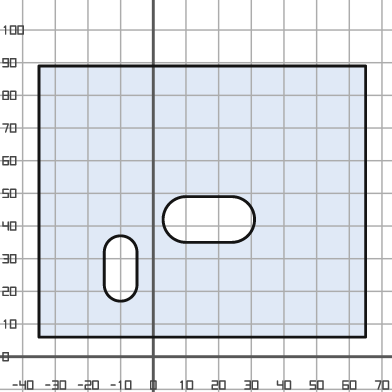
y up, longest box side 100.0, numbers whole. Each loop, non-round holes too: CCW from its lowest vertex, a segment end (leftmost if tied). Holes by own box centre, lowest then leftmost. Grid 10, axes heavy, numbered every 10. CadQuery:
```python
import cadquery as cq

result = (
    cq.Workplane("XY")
    .moveTo(-35.0, 6.0)
    .lineTo(65.0, 6.0)
    .lineTo(65.0, 89.0)
    .lineTo(-35.0, 89.0)
    .close()
    .moveTo(-15.0, 22.0)
    .threePointArc((-10.0, 17.0), (-5.0, 22.0))
    .lineTo(-5.0, 32.0)
    .threePointArc((-10.0, 37.0), (-15.0, 32.0))
    .close()
    .moveTo(10.0, 35.0)
    .lineTo(24.0, 35.0)
    .threePointArc((31.0, 42.0), (24.0, 49.0))
    .lineTo(10.0, 49.0)
    .threePointArc((3.0, 42.0), (10.0, 35.0))
    .close()
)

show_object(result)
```